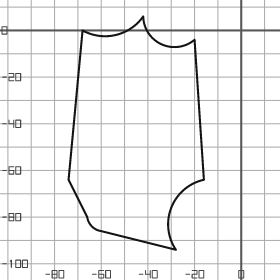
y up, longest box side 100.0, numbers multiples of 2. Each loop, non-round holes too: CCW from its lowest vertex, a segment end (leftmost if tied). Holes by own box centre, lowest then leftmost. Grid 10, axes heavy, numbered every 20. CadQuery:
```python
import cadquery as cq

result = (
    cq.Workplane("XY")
    .moveTo(-28.0, -94.0)
    .threePointArc((-30.0, -76.0), (-16.0, -64.0))
    .lineTo(-20.0, -4.0)
    .threePointArc((-34.0, -6.0), (-42.0, 6.0))
    .threePointArc((-54.0, -2.0), (-68.0, 0.0))
    .lineTo(-74.0, -64.0)
    .lineTo(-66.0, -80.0)
    .threePointArc((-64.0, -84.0), (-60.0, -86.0))
    .close()
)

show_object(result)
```